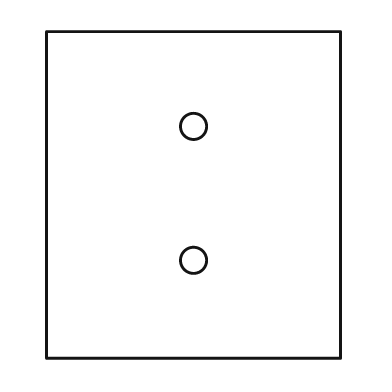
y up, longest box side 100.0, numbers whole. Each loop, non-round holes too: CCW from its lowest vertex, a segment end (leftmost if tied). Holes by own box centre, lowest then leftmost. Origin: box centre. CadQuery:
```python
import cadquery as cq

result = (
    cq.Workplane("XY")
    .moveTo(-45.0, -50.0)
    .lineTo(45.0, -50.0)
    .lineTo(45.0, 50.0)
    .lineTo(-45.0, 50.0)
    .close()
    .moveTo(0.0, -20.0)
    .circle(4.0)
    .moveTo(0.0, 21.0)
    .circle(4.0)
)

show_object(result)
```